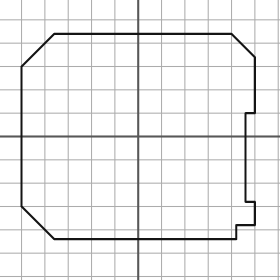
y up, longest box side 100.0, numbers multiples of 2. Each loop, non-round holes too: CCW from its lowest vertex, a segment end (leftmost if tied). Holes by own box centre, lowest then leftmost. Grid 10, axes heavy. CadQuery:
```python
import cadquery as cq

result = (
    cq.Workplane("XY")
    .moveTo(-36.0, -44.0)
    .lineTo(42.0, -44.0)
    .lineTo(42.0, -38.0)
    .lineTo(50.0, -38.0)
    .lineTo(50.0, -28.0)
    .lineTo(46.0, -28.0)
    .lineTo(46.0, 10.0)
    .lineTo(50.0, 10.0)
    .lineTo(50.0, 34.0)
    .lineTo(40.0, 44.0)
    .lineTo(-36.0, 44.0)
    .lineTo(-50.0, 30.0)
    .lineTo(-50.0, -30.0)
    .close()
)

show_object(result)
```